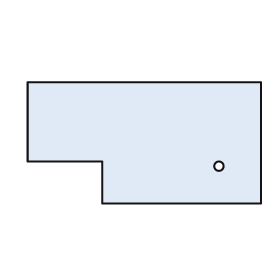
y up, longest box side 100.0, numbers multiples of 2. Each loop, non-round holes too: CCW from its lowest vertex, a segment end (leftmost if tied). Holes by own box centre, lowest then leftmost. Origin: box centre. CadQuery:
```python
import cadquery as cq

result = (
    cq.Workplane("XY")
    .moveTo(-18.0, -26.0)
    .lineTo(50.0, -26.0)
    .lineTo(50.0, 26.0)
    .lineTo(-50.0, 26.0)
    .lineTo(-50.0, -8.0)
    .lineTo(-18.0, -8.0)
    .close()
    .moveTo(32.0, -10.0)
    .circle(2.0)
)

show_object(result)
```